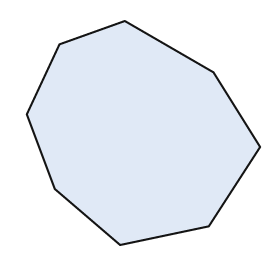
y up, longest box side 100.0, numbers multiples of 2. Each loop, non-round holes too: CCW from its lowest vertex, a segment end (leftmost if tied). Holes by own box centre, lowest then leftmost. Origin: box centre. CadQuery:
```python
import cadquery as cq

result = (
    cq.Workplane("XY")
    .moveTo(-10.0, -48.0)
    .lineTo(28.0, -40.0)
    .lineTo(50.0, -6.0)
    .lineTo(30.0, 26.0)
    .lineTo(-8.0, 48.0)
    .lineTo(-36.0, 38.0)
    .lineTo(-50.0, 8.0)
    .lineTo(-38.0, -24.0)
    .close()
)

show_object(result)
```